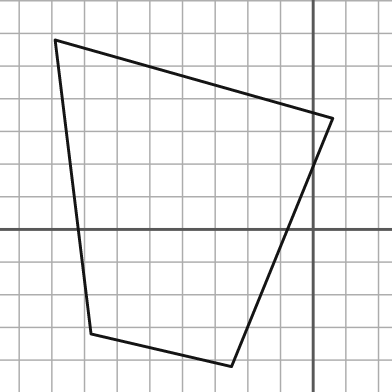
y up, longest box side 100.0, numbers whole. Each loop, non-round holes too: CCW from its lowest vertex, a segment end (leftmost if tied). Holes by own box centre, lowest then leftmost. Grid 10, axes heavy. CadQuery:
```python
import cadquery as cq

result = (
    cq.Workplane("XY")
    .moveTo(-25.0, -42.0)
    .lineTo(6.0, 34.0)
    .lineTo(-79.0, 58.0)
    .lineTo(-68.0, -32.0)
    .close()
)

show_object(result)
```